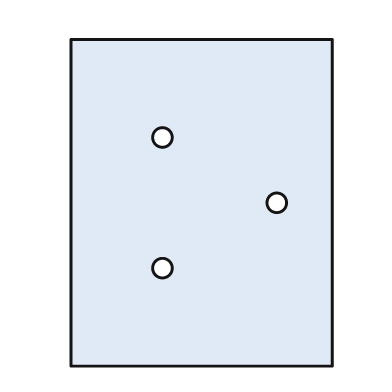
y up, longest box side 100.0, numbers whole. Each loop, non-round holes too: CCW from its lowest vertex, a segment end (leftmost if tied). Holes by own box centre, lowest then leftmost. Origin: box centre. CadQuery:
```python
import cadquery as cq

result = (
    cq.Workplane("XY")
    .moveTo(-40.0, -50.0)
    .lineTo(40.0, -50.0)
    .lineTo(40.0, 50.0)
    .lineTo(-40.0, 50.0)
    .close()
    .moveTo(-12.0, -20.0)
    .circle(3.0)
    .moveTo(23.0, 0.0)
    .circle(3.0)
    .moveTo(-12.0, 20.0)
    .circle(3.0)
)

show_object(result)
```